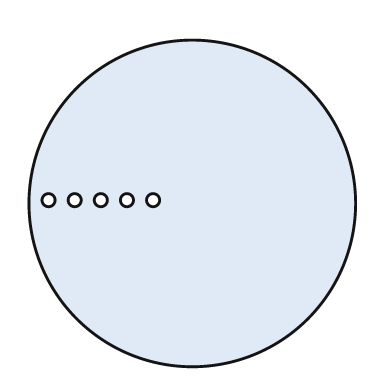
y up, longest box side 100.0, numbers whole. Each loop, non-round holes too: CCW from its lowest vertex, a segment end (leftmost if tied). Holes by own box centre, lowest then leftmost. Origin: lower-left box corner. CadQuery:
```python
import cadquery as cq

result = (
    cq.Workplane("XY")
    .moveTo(50.0, 50.0)
    .circle(50.0)
    .moveTo(6.0, 51.0)
    .circle(2.0)
    .moveTo(14.0, 51.0)
    .circle(2.0)
    .moveTo(22.0, 51.0)
    .circle(2.0)
    .moveTo(30.0, 51.0)
    .circle(2.0)
    .moveTo(38.0, 51.0)
    .circle(2.0)
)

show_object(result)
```